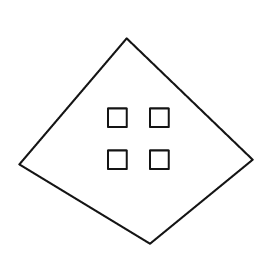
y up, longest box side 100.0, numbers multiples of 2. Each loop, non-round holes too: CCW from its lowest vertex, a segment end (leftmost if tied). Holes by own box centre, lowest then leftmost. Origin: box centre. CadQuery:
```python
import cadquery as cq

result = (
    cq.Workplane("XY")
    .moveTo(6.0, -44.0)
    .lineTo(50.0, -8.0)
    .lineTo(-4.0, 44.0)
    .lineTo(-50.0, -10.0)
    .close()
    .moveTo(-12.0, -12.0)
    .lineTo(-4.0, -12.0)
    .lineTo(-4.0, -4.0)
    .lineTo(-12.0, -4.0)
    .close()
    .moveTo(6.0, -12.0)
    .lineTo(14.0, -12.0)
    .lineTo(14.0, -4.0)
    .lineTo(6.0, -4.0)
    .close()
    .moveTo(-12.0, 6.0)
    .lineTo(-4.0, 6.0)
    .lineTo(-4.0, 14.0)
    .lineTo(-12.0, 14.0)
    .close()
    .moveTo(6.0, 6.0)
    .lineTo(14.0, 6.0)
    .lineTo(14.0, 14.0)
    .lineTo(6.0, 14.0)
    .close()
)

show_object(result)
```